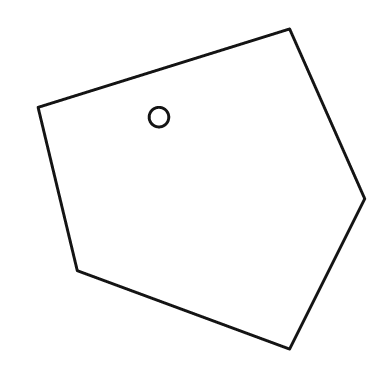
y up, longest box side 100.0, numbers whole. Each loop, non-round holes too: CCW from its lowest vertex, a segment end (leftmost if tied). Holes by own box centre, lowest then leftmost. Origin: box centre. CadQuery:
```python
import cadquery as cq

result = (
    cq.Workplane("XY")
    .moveTo(27.0, -49.0)
    .lineTo(50.0, -3.0)
    .lineTo(27.0, 49.0)
    .lineTo(-50.0, 25.0)
    .lineTo(-38.0, -25.0)
    .close()
    .moveTo(-13.0, 22.0)
    .circle(3.0)
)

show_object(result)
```